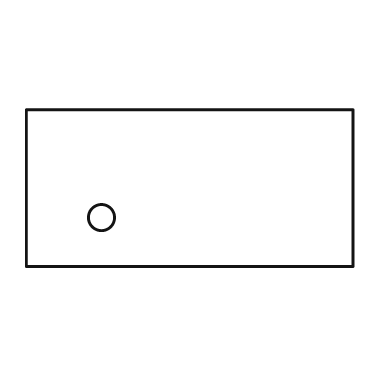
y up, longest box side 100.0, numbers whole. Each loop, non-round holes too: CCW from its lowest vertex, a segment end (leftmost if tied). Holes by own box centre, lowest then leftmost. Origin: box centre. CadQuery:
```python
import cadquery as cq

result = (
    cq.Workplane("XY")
    .moveTo(-50.0, -24.0)
    .lineTo(50.0, -24.0)
    .lineTo(50.0, 24.0)
    .lineTo(-50.0, 24.0)
    .close()
    .moveTo(-27.0, -9.0)
    .circle(4.0)
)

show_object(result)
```